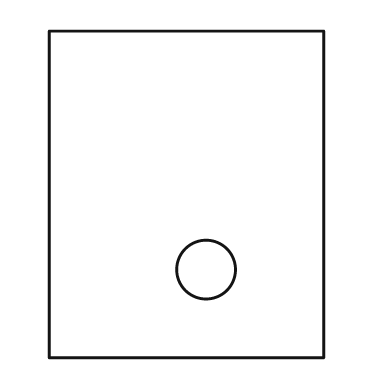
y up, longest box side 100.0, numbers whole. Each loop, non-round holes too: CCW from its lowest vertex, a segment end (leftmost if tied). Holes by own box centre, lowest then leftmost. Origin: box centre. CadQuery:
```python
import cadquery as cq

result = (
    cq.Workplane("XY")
    .moveTo(-42.0, -50.0)
    .lineTo(42.0, -50.0)
    .lineTo(42.0, 50.0)
    .lineTo(-42.0, 50.0)
    .close()
    .moveTo(6.0, -23.0)
    .circle(9.0)
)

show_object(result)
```